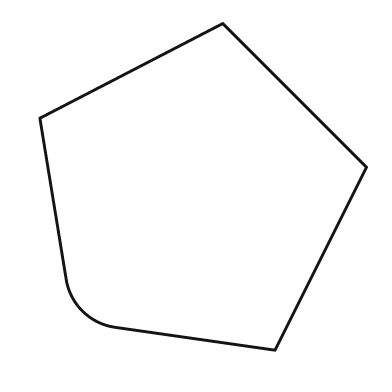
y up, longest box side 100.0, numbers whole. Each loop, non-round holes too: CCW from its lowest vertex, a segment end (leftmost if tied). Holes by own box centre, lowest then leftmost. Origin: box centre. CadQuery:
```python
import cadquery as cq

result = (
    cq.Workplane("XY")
    .moveTo(22.0, -50.0)
    .lineTo(50.0, 6.0)
    .lineTo(6.0, 50.0)
    .lineTo(-50.0, 21.0)
    .lineTo(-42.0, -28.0)
    .threePointArc((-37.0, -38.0), (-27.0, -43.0))
    .close()
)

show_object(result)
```